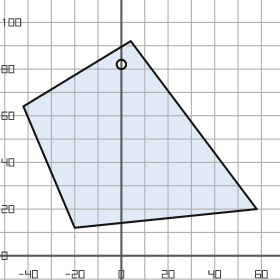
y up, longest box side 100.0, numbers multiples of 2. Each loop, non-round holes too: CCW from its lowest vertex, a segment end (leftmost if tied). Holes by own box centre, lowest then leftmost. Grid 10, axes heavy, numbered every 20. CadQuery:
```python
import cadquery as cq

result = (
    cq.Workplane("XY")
    .moveTo(-20.0, 12.0)
    .lineTo(58.0, 20.0)
    .lineTo(4.0, 92.0)
    .lineTo(-42.0, 64.0)
    .close()
    .moveTo(0.0, 82.0)
    .circle(2.0)
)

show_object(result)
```